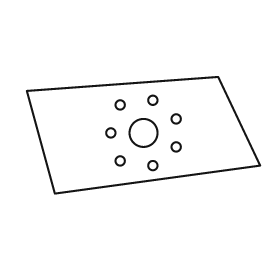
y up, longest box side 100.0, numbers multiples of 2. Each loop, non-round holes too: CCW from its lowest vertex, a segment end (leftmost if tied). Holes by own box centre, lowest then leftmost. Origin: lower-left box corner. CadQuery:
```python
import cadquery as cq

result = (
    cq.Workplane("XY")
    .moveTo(12.0, 0.0)
    .lineTo(100.0, 12.0)
    .lineTo(82.0, 50.0)
    .lineTo(0.0, 44.0)
    .close()
    .moveTo(54.0, 12.0)
    .circle(2.0)
    .moveTo(40.0, 14.0)
    .circle(2.0)
    .moveTo(64.0, 20.0)
    .circle(2.0)
    .moveTo(36.0, 26.0)
    .circle(2.0)
    .moveTo(50.0, 26.0)
    .circle(6.0)
    .moveTo(64.0, 32.0)
    .circle(2.0)
    .moveTo(40.0, 38.0)
    .circle(2.0)
    .moveTo(54.0, 40.0)
    .circle(2.0)
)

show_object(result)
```